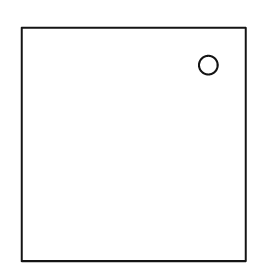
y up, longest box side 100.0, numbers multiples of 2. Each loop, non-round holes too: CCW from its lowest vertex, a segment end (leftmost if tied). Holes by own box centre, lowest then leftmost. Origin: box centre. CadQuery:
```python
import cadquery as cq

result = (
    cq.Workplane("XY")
    .moveTo(-48.0, -50.0)
    .lineTo(48.0, -50.0)
    .lineTo(48.0, 50.0)
    .lineTo(-48.0, 50.0)
    .close()
    .moveTo(32.0, 34.0)
    .circle(4.0)
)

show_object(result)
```